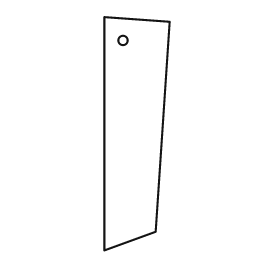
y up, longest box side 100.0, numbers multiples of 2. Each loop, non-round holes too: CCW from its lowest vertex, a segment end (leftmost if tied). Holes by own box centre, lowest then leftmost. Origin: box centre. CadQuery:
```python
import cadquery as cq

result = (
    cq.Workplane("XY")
    .moveTo(-14.0, -50.0)
    .lineTo(8.0, -42.0)
    .lineTo(14.0, 48.0)
    .lineTo(-14.0, 50.0)
    .close()
    .moveTo(-6.0, 40.0)
    .circle(2.0)
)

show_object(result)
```